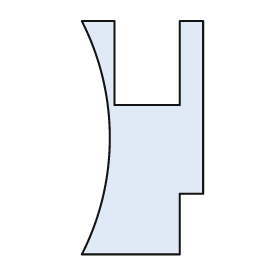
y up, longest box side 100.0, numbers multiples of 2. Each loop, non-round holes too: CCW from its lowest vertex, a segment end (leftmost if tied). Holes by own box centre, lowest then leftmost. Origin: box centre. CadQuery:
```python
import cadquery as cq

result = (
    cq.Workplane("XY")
    .moveTo(-26.0, -50.0)
    .lineTo(16.0, -50.0)
    .lineTo(16.0, -24.0)
    .lineTo(26.0, -24.0)
    .lineTo(26.0, 50.0)
    .lineTo(16.0, 50.0)
    .lineTo(16.0, 14.0)
    .lineTo(-12.0, 14.0)
    .lineTo(-12.0, 50.0)
    .lineTo(-26.0, 50.0)
    .threePointArc((-14.0, 0.0), (-26.0, -50.0))
    .close()
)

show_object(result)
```